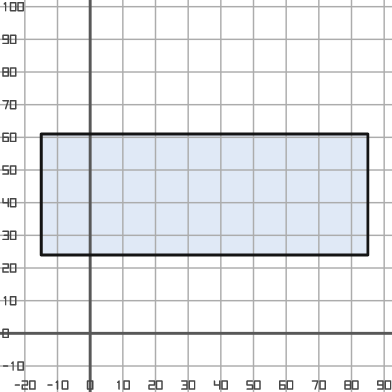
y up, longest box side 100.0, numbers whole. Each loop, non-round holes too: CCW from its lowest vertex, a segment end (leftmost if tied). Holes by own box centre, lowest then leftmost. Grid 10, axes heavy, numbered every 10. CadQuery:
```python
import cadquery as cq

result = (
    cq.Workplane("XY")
    .moveTo(-15.0, 24.0)
    .lineTo(85.0, 24.0)
    .lineTo(85.0, 61.0)
    .lineTo(-15.0, 61.0)
    .close()
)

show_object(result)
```